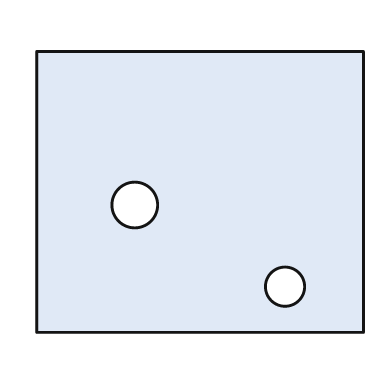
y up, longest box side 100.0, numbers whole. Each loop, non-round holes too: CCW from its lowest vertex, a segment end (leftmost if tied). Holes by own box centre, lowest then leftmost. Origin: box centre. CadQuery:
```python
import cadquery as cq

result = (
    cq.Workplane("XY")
    .moveTo(-50.0, -43.0)
    .lineTo(50.0, -43.0)
    .lineTo(50.0, 43.0)
    .lineTo(-50.0, 43.0)
    .close()
    .moveTo(26.0, -29.0)
    .circle(6.0)
    .moveTo(-20.0, -4.0)
    .circle(7.0)
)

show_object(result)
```